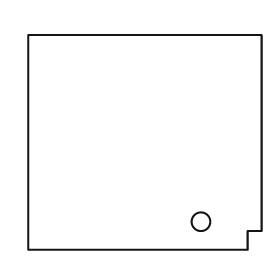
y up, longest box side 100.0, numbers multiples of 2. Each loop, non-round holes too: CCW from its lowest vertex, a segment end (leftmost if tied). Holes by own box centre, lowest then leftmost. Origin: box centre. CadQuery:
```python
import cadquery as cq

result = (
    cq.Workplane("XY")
    .moveTo(-50.0, -46.0)
    .lineTo(44.0, -46.0)
    .lineTo(44.0, -38.0)
    .lineTo(50.0, -38.0)
    .lineTo(50.0, 46.0)
    .lineTo(-50.0, 46.0)
    .close()
    .moveTo(24.0, -34.0)
    .circle(4.0)
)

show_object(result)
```